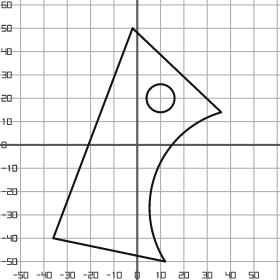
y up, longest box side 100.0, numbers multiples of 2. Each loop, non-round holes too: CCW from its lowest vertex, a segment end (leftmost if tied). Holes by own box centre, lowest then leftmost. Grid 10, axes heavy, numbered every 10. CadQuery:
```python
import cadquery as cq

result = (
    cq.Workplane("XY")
    .moveTo(12.0, -50.0)
    .threePointArc((8.0, -12.0), (36.0, 14.0))
    .lineTo(-2.0, 50.0)
    .lineTo(-36.0, -40.0)
    .close()
    .moveTo(10.0, 20.0)
    .circle(6.0)
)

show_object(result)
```